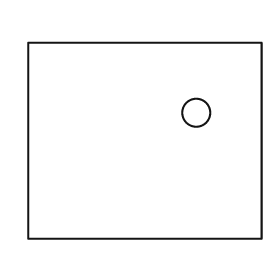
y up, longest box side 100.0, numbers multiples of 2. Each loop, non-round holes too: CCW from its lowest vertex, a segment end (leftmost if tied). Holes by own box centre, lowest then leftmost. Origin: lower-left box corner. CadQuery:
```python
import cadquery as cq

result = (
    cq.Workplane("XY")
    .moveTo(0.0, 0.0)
    .lineTo(100.0, 0.0)
    .lineTo(100.0, 84.0)
    .lineTo(0.0, 84.0)
    .close()
    .moveTo(72.0, 54.0)
    .circle(6.0)
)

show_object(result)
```